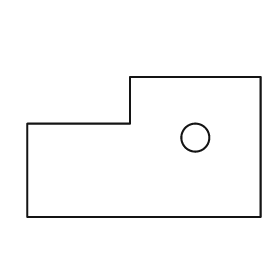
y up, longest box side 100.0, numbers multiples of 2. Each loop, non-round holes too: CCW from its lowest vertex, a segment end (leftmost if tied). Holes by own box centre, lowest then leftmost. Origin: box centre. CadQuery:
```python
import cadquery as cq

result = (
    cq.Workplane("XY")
    .moveTo(-50.0, -30.0)
    .lineTo(50.0, -30.0)
    .lineTo(50.0, 30.0)
    .lineTo(-6.0, 30.0)
    .lineTo(-6.0, 10.0)
    .lineTo(-50.0, 10.0)
    .close()
    .moveTo(22.0, 4.0)
    .circle(6.0)
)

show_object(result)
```